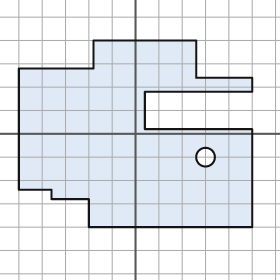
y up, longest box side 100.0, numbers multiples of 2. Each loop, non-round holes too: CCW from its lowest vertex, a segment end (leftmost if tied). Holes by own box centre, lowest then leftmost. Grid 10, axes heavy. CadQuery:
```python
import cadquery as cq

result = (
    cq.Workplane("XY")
    .moveTo(-20.0, -40.0)
    .lineTo(50.0, -40.0)
    .lineTo(50.0, 2.0)
    .lineTo(4.0, 2.0)
    .lineTo(4.0, 18.0)
    .lineTo(50.0, 18.0)
    .lineTo(50.0, 24.0)
    .lineTo(26.0, 24.0)
    .lineTo(26.0, 40.0)
    .lineTo(-18.0, 40.0)
    .lineTo(-18.0, 28.0)
    .lineTo(-50.0, 28.0)
    .lineTo(-50.0, -24.0)
    .lineTo(-36.0, -24.0)
    .lineTo(-36.0, -28.0)
    .lineTo(-20.0, -28.0)
    .close()
    .moveTo(30.0, -10.0)
    .circle(4.0)
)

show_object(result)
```